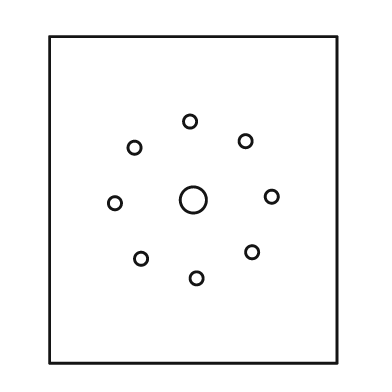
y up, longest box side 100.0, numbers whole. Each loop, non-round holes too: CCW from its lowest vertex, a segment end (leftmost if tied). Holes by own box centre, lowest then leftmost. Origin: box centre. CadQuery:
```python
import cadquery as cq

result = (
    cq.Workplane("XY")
    .moveTo(-44.0, -50.0)
    .lineTo(44.0, -50.0)
    .lineTo(44.0, 50.0)
    .lineTo(-44.0, 50.0)
    .close()
    .moveTo(1.0, -24.0)
    .circle(2.0)
    .moveTo(-16.0, -18.0)
    .circle(2.0)
    .moveTo(18.0, -16.0)
    .circle(2.0)
    .moveTo(-24.0, -1.0)
    .circle(2.0)
    .moveTo(0.0, 0.0)
    .circle(4.0)
    .moveTo(24.0, 1.0)
    .circle(2.0)
    .moveTo(-18.0, 16.0)
    .circle(2.0)
    .moveTo(16.0, 18.0)
    .circle(2.0)
    .moveTo(-1.0, 24.0)
    .circle(2.0)
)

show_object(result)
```